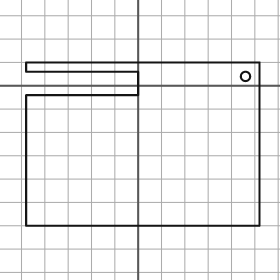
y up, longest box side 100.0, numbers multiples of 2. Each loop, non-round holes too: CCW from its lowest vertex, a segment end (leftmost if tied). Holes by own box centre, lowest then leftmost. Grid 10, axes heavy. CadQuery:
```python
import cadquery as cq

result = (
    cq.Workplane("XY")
    .moveTo(-48.0, -60.0)
    .lineTo(52.0, -60.0)
    .lineTo(52.0, 10.0)
    .lineTo(-48.0, 10.0)
    .lineTo(-48.0, 6.0)
    .lineTo(0.0, 6.0)
    .lineTo(0.0, -4.0)
    .lineTo(-48.0, -4.0)
    .close()
    .moveTo(46.0, 4.0)
    .circle(2.0)
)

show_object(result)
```